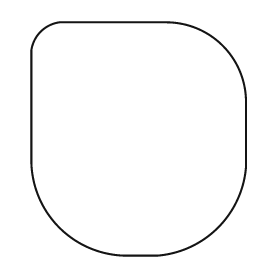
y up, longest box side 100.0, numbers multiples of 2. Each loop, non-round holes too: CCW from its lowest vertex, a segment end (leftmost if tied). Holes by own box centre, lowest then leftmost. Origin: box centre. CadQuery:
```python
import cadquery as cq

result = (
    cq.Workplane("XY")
    .moveTo(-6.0, -50.0)
    .lineTo(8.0, -50.0)
    .threePointArc((34.0, -38.0), (46.0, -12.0))
    .lineTo(46.0, 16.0)
    .threePointArc((36.0, 40.0), (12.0, 50.0))
    .lineTo(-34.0, 50.0)
    .threePointArc((-42.0, 46.0), (-46.0, 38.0))
    .lineTo(-46.0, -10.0)
    .threePointArc((-34.0, -38.0), (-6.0, -50.0))
    .close()
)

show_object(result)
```